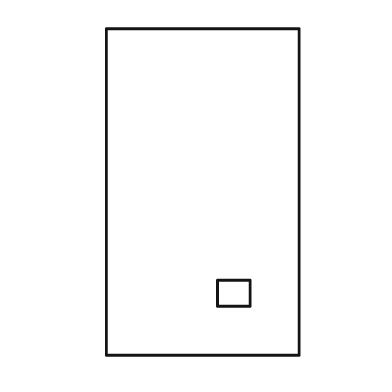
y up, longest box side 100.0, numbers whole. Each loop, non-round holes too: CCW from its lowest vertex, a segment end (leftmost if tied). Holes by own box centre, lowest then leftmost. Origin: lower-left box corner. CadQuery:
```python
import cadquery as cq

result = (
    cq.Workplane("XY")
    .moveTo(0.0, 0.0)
    .lineTo(59.0, 0.0)
    .lineTo(59.0, 100.0)
    .lineTo(0.0, 100.0)
    .close()
    .moveTo(34.0, 15.0)
    .lineTo(44.0, 15.0)
    .lineTo(44.0, 23.0)
    .lineTo(34.0, 23.0)
    .close()
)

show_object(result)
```